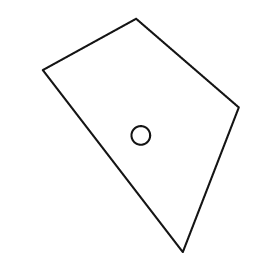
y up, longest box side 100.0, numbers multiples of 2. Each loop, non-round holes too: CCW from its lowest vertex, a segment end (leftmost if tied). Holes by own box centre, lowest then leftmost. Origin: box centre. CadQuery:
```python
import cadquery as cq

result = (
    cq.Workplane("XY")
    .moveTo(18.0, -50.0)
    .lineTo(42.0, 12.0)
    .lineTo(-2.0, 50.0)
    .lineTo(-42.0, 28.0)
    .close()
    .moveTo(0.0, 0.0)
    .circle(4.0)
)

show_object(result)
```